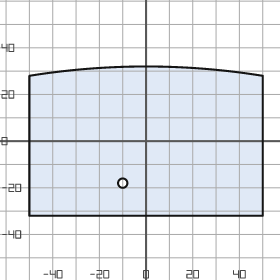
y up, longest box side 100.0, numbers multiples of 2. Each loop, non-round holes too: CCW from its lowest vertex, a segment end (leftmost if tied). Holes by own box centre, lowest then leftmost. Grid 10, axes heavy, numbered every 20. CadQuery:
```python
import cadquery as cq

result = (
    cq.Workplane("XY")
    .moveTo(-50.0, -32.0)
    .lineTo(50.0, -32.0)
    .lineTo(50.0, 28.0)
    .threePointArc((0.0, 32.0), (-50.0, 28.0))
    .close()
    .moveTo(-10.0, -18.0)
    .circle(2.0)
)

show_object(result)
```